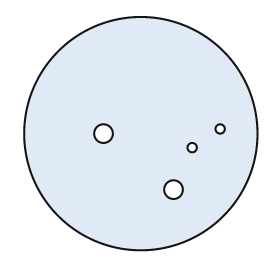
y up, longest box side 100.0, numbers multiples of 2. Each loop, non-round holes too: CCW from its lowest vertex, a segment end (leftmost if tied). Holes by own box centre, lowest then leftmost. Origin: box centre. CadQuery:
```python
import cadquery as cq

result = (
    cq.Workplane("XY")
    .moveTo(0.0, 0.0)
    .circle(50.0)
    .moveTo(14.0, -24.0)
    .circle(4.0)
    .moveTo(22.0, -6.0)
    .circle(2.0)
    .moveTo(-16.0, 0.0)
    .circle(4.0)
    .moveTo(34.0, 2.0)
    .circle(2.0)
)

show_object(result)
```